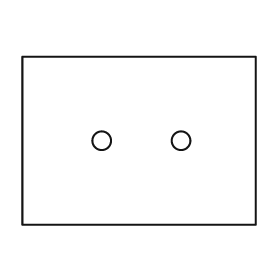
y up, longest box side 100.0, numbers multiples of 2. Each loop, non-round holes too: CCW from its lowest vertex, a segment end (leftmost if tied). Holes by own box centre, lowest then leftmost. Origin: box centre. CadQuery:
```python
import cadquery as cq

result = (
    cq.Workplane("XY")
    .moveTo(-50.0, -36.0)
    .lineTo(50.0, -36.0)
    .lineTo(50.0, 36.0)
    .lineTo(-50.0, 36.0)
    .close()
    .moveTo(-16.0, 0.0)
    .circle(4.0)
    .moveTo(18.0, 0.0)
    .circle(4.0)
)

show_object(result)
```